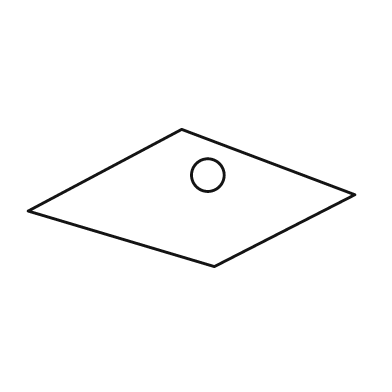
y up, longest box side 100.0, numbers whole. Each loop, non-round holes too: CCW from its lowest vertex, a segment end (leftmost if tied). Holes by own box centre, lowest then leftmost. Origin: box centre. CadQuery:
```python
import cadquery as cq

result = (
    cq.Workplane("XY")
    .moveTo(7.0, -21.0)
    .lineTo(50.0, 1.0)
    .lineTo(-3.0, 21.0)
    .lineTo(-50.0, -4.0)
    .close()
    .moveTo(5.0, 7.0)
    .circle(5.0)
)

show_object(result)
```